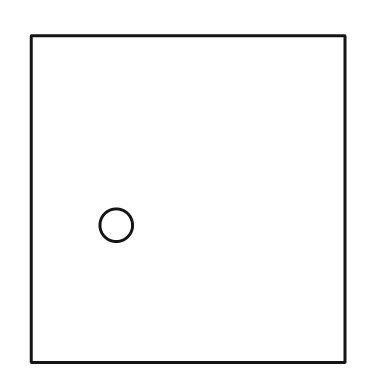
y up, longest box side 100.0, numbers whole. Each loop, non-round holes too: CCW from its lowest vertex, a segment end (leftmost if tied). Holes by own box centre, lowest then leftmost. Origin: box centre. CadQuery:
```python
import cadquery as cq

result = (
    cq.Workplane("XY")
    .moveTo(-48.0, -50.0)
    .lineTo(48.0, -50.0)
    .lineTo(48.0, 50.0)
    .lineTo(-48.0, 50.0)
    .close()
    .moveTo(-22.0, -8.0)
    .circle(5.0)
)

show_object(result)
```